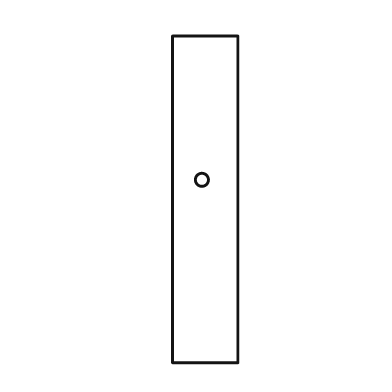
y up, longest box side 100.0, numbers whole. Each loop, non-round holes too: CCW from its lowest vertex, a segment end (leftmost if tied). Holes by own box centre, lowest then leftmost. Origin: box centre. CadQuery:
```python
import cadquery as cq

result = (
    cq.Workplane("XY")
    .moveTo(-10.0, -50.0)
    .lineTo(10.0, -50.0)
    .lineTo(10.0, 50.0)
    .lineTo(-10.0, 50.0)
    .close()
    .moveTo(-1.0, 6.0)
    .circle(2.0)
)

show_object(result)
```